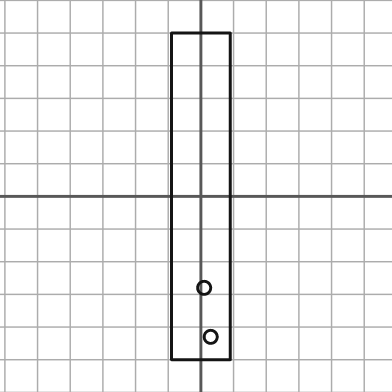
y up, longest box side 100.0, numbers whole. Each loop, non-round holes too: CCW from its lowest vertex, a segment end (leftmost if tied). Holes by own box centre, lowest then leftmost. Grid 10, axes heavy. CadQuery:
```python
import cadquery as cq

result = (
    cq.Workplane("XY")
    .moveTo(-9.0, -50.0)
    .lineTo(9.0, -50.0)
    .lineTo(9.0, 50.0)
    .lineTo(-9.0, 50.0)
    .close()
    .moveTo(3.0, -43.0)
    .circle(2.0)
    .moveTo(1.0, -28.0)
    .circle(2.0)
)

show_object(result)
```